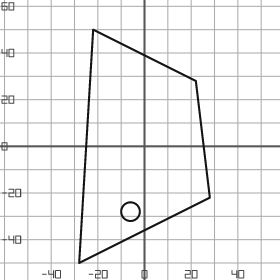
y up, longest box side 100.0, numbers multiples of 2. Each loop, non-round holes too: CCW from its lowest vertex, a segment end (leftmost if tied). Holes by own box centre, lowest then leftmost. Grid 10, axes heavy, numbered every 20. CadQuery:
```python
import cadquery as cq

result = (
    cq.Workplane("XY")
    .moveTo(-28.0, -50.0)
    .lineTo(28.0, -22.0)
    .lineTo(22.0, 28.0)
    .lineTo(-22.0, 50.0)
    .close()
    .moveTo(-6.0, -28.0)
    .circle(4.0)
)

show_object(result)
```